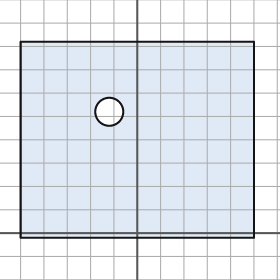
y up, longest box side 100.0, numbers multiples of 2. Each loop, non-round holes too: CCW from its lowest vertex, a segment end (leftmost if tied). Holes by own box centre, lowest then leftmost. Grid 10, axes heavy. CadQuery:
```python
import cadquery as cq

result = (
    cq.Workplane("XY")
    .moveTo(-50.0, -2.0)
    .lineTo(50.0, -2.0)
    .lineTo(50.0, 82.0)
    .lineTo(-50.0, 82.0)
    .close()
    .moveTo(-12.0, 52.0)
    .circle(6.0)
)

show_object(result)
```